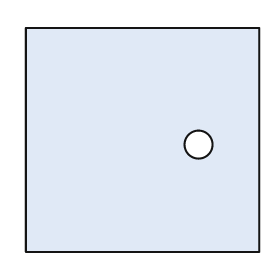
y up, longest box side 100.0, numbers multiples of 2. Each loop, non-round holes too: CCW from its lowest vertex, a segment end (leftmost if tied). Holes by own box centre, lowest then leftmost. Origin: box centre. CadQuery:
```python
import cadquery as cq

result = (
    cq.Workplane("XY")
    .moveTo(-50.0, -48.0)
    .lineTo(50.0, -48.0)
    .lineTo(50.0, 48.0)
    .lineTo(-50.0, 48.0)
    .close()
    .moveTo(24.0, -2.0)
    .circle(6.0)
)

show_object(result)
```